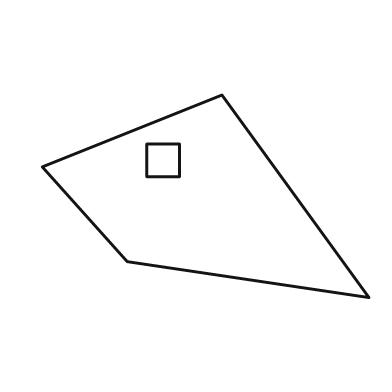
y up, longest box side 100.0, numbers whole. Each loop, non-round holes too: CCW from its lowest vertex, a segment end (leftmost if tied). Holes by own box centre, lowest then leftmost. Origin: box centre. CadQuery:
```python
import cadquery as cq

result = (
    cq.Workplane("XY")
    .moveTo(50.0, -31.0)
    .lineTo(5.0, 31.0)
    .lineTo(-50.0, 9.0)
    .lineTo(-24.0, -20.0)
    .close()
    .moveTo(-18.0, 6.0)
    .lineTo(-8.0, 6.0)
    .lineTo(-8.0, 16.0)
    .lineTo(-18.0, 16.0)
    .close()
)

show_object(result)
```